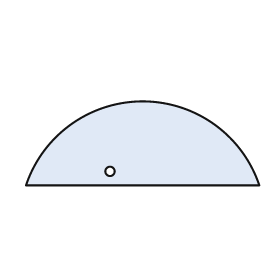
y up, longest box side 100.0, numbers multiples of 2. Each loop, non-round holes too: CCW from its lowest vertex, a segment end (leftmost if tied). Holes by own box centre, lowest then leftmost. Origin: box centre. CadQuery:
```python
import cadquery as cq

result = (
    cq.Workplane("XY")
    .moveTo(-50.0, -18.0)
    .lineTo(50.0, -18.0)
    .threePointArc((0.0, 18.0), (-50.0, -18.0))
    .close()
    .moveTo(-14.0, -12.0)
    .circle(2.0)
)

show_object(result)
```